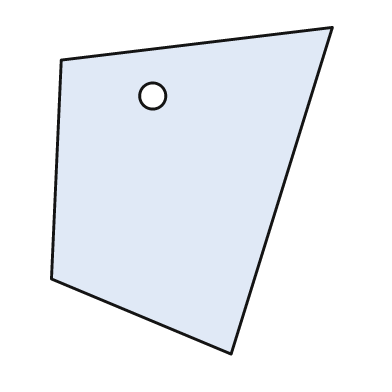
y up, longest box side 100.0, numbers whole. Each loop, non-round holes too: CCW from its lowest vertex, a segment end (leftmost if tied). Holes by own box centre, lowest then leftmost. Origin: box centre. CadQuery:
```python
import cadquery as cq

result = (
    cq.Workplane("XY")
    .moveTo(12.0, -50.0)
    .lineTo(43.0, 50.0)
    .lineTo(-40.0, 40.0)
    .lineTo(-43.0, -27.0)
    .close()
    .moveTo(-12.0, 29.0)
    .circle(4.0)
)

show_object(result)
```